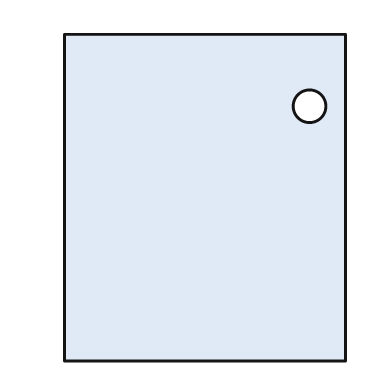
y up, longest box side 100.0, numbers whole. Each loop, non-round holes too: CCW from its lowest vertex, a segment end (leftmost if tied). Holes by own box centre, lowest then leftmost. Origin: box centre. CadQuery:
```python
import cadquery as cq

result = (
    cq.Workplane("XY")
    .moveTo(-43.0, -50.0)
    .lineTo(43.0, -50.0)
    .lineTo(43.0, 50.0)
    .lineTo(-43.0, 50.0)
    .close()
    .moveTo(32.0, 28.0)
    .circle(5.0)
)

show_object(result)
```